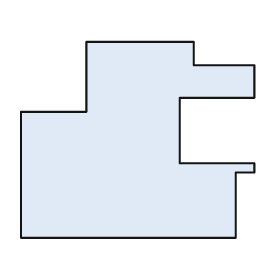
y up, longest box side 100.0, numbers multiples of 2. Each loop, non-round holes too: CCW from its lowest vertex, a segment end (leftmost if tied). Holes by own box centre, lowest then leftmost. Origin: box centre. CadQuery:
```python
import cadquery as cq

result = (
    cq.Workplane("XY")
    .moveTo(-50.0, -42.0)
    .lineTo(42.0, -42.0)
    .lineTo(42.0, -14.0)
    .lineTo(50.0, -14.0)
    .lineTo(50.0, -10.0)
    .lineTo(18.0, -10.0)
    .lineTo(18.0, 18.0)
    .lineTo(50.0, 18.0)
    .lineTo(50.0, 32.0)
    .lineTo(24.0, 32.0)
    .lineTo(24.0, 42.0)
    .lineTo(-22.0, 42.0)
    .lineTo(-22.0, 12.0)
    .lineTo(-50.0, 12.0)
    .close()
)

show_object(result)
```